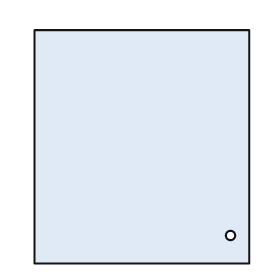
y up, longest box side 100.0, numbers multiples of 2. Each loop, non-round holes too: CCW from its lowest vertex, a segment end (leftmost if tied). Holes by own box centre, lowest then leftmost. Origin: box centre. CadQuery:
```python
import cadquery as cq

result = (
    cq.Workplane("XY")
    .moveTo(-46.0, -50.0)
    .lineTo(46.0, -50.0)
    .lineTo(46.0, 50.0)
    .lineTo(-46.0, 50.0)
    .close()
    .moveTo(38.0, -38.0)
    .circle(2.0)
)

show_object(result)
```